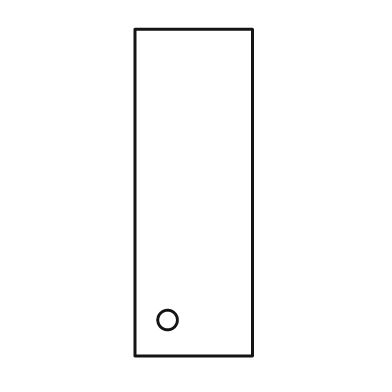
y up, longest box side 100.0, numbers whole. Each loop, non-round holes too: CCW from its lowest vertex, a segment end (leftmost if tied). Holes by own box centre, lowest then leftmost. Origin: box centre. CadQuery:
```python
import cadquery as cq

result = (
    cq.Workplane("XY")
    .moveTo(-18.0, -50.0)
    .lineTo(18.0, -50.0)
    .lineTo(18.0, 50.0)
    .lineTo(-18.0, 50.0)
    .close()
    .moveTo(-8.0, -39.0)
    .circle(3.0)
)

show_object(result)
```